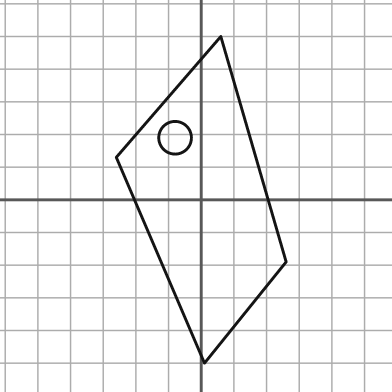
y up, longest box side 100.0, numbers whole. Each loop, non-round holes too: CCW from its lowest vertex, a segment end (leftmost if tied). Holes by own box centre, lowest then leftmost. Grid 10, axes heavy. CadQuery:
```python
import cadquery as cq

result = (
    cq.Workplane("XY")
    .moveTo(1.0, -50.0)
    .lineTo(26.0, -19.0)
    .lineTo(6.0, 50.0)
    .lineTo(-26.0, 13.0)
    .close()
    .moveTo(-8.0, 19.0)
    .circle(5.0)
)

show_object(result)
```